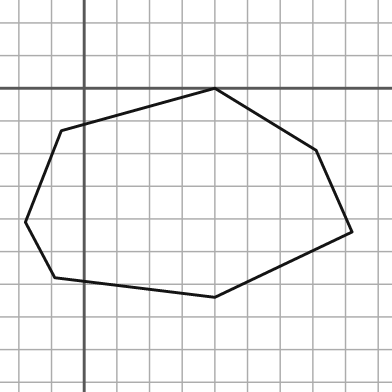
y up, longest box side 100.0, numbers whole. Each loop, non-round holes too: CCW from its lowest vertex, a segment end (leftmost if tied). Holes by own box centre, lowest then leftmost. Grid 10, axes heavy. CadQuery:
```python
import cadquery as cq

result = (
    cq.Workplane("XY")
    .moveTo(40.0, -64.0)
    .lineTo(82.0, -44.0)
    .lineTo(71.0, -19.0)
    .lineTo(40.0, 0.0)
    .lineTo(-7.0, -13.0)
    .lineTo(-18.0, -41.0)
    .lineTo(-9.0, -58.0)
    .close()
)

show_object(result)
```